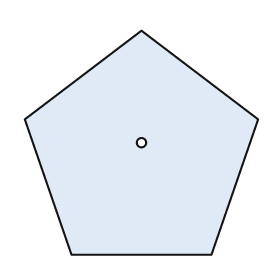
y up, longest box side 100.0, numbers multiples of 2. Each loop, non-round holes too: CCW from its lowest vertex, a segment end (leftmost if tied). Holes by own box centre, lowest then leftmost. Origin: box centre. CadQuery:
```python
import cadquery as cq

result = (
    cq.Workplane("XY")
    .moveTo(-30.0, -48.0)
    .lineTo(30.0, -48.0)
    .lineTo(50.0, 10.0)
    .lineTo(0.0, 48.0)
    .lineTo(-50.0, 10.0)
    .close()
    .moveTo(0.0, 0.0)
    .circle(2.0)
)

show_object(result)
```